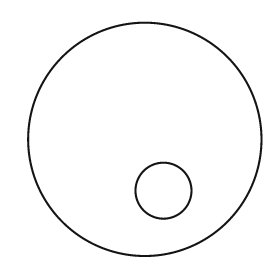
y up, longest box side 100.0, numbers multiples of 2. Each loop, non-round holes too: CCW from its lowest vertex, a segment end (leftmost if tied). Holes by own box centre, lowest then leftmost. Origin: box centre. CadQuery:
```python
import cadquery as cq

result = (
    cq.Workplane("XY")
    .moveTo(0.0, 0.0)
    .circle(50.0)
    .moveTo(8.0, -22.0)
    .circle(12.0)
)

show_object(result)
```